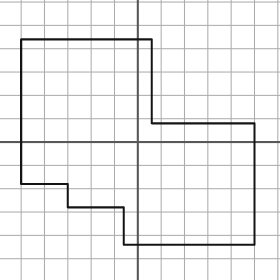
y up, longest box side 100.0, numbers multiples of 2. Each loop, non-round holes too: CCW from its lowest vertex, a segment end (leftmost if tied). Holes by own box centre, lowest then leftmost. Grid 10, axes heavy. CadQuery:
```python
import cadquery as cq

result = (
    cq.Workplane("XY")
    .moveTo(-6.0, -44.0)
    .lineTo(50.0, -44.0)
    .lineTo(50.0, 8.0)
    .lineTo(6.0, 8.0)
    .lineTo(6.0, 44.0)
    .lineTo(-50.0, 44.0)
    .lineTo(-50.0, -18.0)
    .lineTo(-30.0, -18.0)
    .lineTo(-30.0, -28.0)
    .lineTo(-6.0, -28.0)
    .close()
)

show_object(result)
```